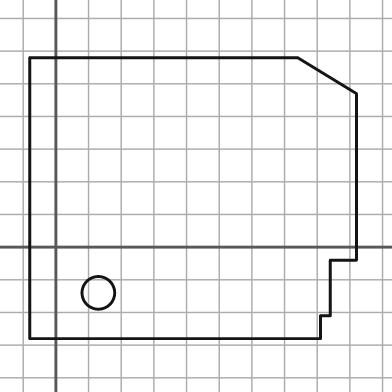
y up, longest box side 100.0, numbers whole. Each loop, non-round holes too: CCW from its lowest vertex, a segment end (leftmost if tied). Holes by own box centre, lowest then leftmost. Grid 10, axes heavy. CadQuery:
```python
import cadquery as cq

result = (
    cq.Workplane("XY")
    .moveTo(-8.0, -28.0)
    .lineTo(81.0, -28.0)
    .lineTo(81.0, -21.0)
    .lineTo(84.0, -21.0)
    .lineTo(84.0, -4.0)
    .lineTo(92.0, -4.0)
    .lineTo(92.0, 47.0)
    .lineTo(74.0, 58.0)
    .lineTo(-8.0, 58.0)
    .close()
    .moveTo(13.0, -14.0)
    .circle(5.0)
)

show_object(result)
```